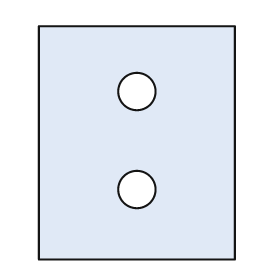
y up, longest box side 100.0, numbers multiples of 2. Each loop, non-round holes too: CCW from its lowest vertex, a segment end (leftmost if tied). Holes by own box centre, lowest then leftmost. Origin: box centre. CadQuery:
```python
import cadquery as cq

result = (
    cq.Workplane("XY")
    .moveTo(-42.0, -50.0)
    .lineTo(42.0, -50.0)
    .lineTo(42.0, 50.0)
    .lineTo(-42.0, 50.0)
    .close()
    .moveTo(0.0, -20.0)
    .circle(8.0)
    .moveTo(0.0, 22.0)
    .circle(8.0)
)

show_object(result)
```